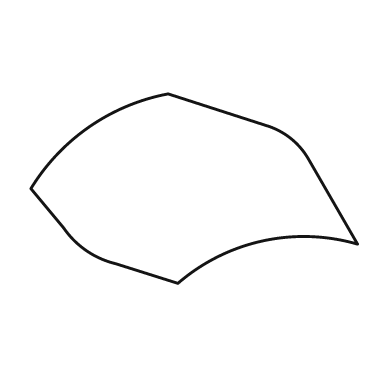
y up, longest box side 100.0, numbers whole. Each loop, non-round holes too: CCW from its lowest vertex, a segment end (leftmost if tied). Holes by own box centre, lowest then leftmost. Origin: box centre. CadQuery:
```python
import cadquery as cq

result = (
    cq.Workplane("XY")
    .moveTo(-5.0, -29.0)
    .threePointArc((21.0, -16.0), (50.0, -17.0))
    .lineTo(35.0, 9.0)
    .threePointArc((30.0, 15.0), (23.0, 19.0))
    .lineTo(-8.0, 29.0)
    .threePointArc((-32.0, 19.0), (-50.0, 0.0))
    .lineTo(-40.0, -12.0)
    .threePointArc((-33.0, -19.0), (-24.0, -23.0))
    .close()
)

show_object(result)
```